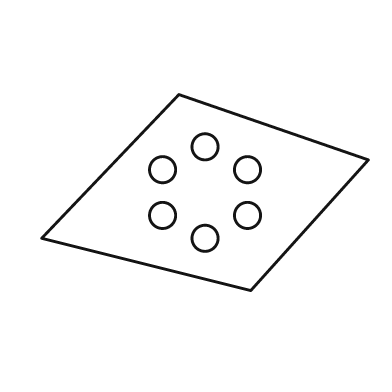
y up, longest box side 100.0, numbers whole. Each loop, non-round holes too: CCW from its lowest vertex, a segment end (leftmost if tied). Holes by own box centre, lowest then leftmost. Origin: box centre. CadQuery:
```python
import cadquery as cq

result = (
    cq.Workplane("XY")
    .moveTo(14.0, -30.0)
    .lineTo(50.0, 10.0)
    .lineTo(-8.0, 30.0)
    .lineTo(-50.0, -14.0)
    .close()
    .moveTo(0.0, -14.0)
    .circle(4.0)
    .moveTo(-13.0, -7.0)
    .circle(4.0)
    .moveTo(13.0, -7.0)
    .circle(4.0)
    .moveTo(-13.0, 7.0)
    .circle(4.0)
    .moveTo(13.0, 7.0)
    .circle(4.0)
    .moveTo(0.0, 14.0)
    .circle(4.0)
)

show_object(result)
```